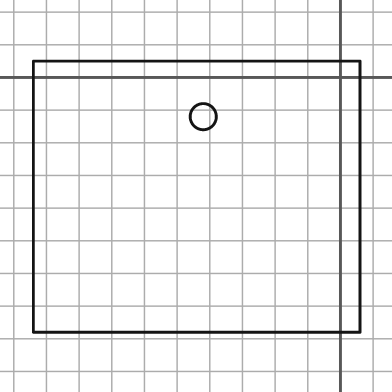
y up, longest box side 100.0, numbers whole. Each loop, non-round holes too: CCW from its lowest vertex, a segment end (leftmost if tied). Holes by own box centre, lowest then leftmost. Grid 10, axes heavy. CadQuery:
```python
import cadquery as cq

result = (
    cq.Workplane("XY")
    .moveTo(-94.0, -78.0)
    .lineTo(6.0, -78.0)
    .lineTo(6.0, 5.0)
    .lineTo(-94.0, 5.0)
    .close()
    .moveTo(-42.0, -12.0)
    .circle(4.0)
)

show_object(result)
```